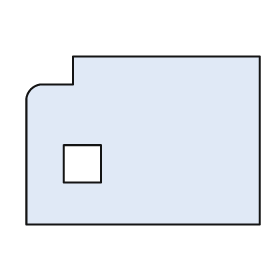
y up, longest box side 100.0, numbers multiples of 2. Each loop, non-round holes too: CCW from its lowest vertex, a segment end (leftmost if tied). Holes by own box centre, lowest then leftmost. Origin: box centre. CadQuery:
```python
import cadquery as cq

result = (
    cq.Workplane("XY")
    .moveTo(-50.0, -36.0)
    .lineTo(50.0, -36.0)
    .lineTo(50.0, 36.0)
    .lineTo(-30.0, 36.0)
    .lineTo(-30.0, 24.0)
    .lineTo(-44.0, 24.0)
    .threePointArc((-48.0, 22.0), (-50.0, 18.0))
    .close()
    .moveTo(-34.0, -18.0)
    .lineTo(-18.0, -18.0)
    .lineTo(-18.0, -2.0)
    .lineTo(-34.0, -2.0)
    .close()
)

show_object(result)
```